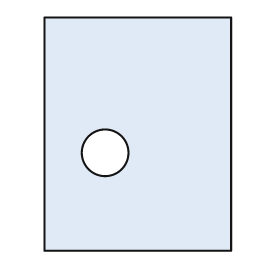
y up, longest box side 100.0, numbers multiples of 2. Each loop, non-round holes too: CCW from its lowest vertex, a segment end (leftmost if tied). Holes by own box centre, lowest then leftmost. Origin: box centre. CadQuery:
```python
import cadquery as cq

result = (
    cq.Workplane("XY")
    .moveTo(-40.0, -50.0)
    .lineTo(40.0, -50.0)
    .lineTo(40.0, 50.0)
    .lineTo(-40.0, 50.0)
    .close()
    .moveTo(-14.0, -8.0)
    .circle(10.0)
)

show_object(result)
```